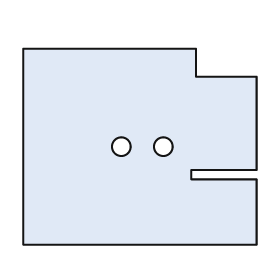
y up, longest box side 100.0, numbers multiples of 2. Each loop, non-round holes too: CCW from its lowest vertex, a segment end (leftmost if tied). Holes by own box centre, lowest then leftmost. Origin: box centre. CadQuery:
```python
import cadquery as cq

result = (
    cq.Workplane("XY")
    .moveTo(-50.0, -42.0)
    .lineTo(50.0, -42.0)
    .lineTo(50.0, -14.0)
    .lineTo(22.0, -14.0)
    .lineTo(22.0, -10.0)
    .lineTo(50.0, -10.0)
    .lineTo(50.0, 30.0)
    .lineTo(24.0, 30.0)
    .lineTo(24.0, 42.0)
    .lineTo(-50.0, 42.0)
    .close()
    .moveTo(-8.0, 0.0)
    .circle(4.0)
    .moveTo(10.0, 0.0)
    .circle(4.0)
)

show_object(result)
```